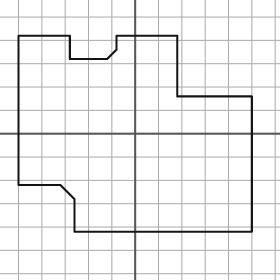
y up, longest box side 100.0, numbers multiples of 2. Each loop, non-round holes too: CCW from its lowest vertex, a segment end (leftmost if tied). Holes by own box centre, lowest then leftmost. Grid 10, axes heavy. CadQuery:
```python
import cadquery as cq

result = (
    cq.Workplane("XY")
    .moveTo(-26.0, -42.0)
    .lineTo(50.0, -42.0)
    .lineTo(50.0, 16.0)
    .lineTo(18.0, 16.0)
    .lineTo(18.0, 42.0)
    .lineTo(-8.0, 42.0)
    .lineTo(-8.0, 36.0)
    .lineTo(-12.0, 32.0)
    .lineTo(-28.0, 32.0)
    .lineTo(-28.0, 42.0)
    .lineTo(-50.0, 42.0)
    .lineTo(-50.0, -22.0)
    .lineTo(-32.0, -22.0)
    .lineTo(-26.0, -28.0)
    .close()
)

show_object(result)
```